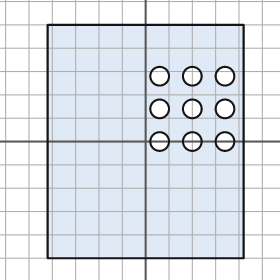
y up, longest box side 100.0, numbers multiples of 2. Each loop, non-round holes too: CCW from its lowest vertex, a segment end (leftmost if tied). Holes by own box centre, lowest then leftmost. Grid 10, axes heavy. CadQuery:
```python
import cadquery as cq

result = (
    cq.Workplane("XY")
    .moveTo(-42.0, -50.0)
    .lineTo(42.0, -50.0)
    .lineTo(42.0, 50.0)
    .lineTo(-42.0, 50.0)
    .close()
    .moveTo(6.0, 0.0)
    .circle(4.0)
    .moveTo(20.0, 0.0)
    .circle(4.0)
    .moveTo(34.0, 0.0)
    .circle(4.0)
    .moveTo(6.0, 14.0)
    .circle(4.0)
    .moveTo(20.0, 14.0)
    .circle(4.0)
    .moveTo(34.0, 14.0)
    .circle(4.0)
    .moveTo(6.0, 28.0)
    .circle(4.0)
    .moveTo(20.0, 28.0)
    .circle(4.0)
    .moveTo(34.0, 28.0)
    .circle(4.0)
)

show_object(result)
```